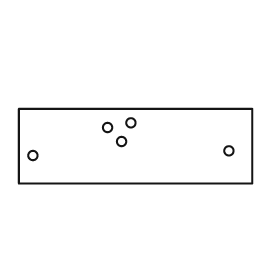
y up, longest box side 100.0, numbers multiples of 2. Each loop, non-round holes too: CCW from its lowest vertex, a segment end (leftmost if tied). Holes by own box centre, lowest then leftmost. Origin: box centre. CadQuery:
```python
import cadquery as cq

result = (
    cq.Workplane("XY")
    .moveTo(-50.0, -16.0)
    .lineTo(50.0, -16.0)
    .lineTo(50.0, 16.0)
    .lineTo(-50.0, 16.0)
    .close()
    .moveTo(-44.0, -4.0)
    .circle(2.0)
    .moveTo(40.0, -2.0)
    .circle(2.0)
    .moveTo(-6.0, 2.0)
    .circle(2.0)
    .moveTo(-12.0, 8.0)
    .circle(2.0)
    .moveTo(-2.0, 10.0)
    .circle(2.0)
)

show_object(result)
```